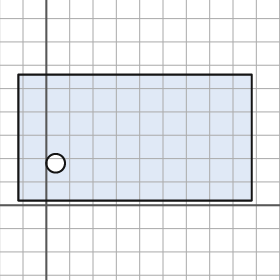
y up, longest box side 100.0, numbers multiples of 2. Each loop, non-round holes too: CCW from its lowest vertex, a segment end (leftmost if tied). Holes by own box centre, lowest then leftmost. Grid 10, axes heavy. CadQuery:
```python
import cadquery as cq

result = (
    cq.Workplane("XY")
    .moveTo(-12.0, 2.0)
    .lineTo(88.0, 2.0)
    .lineTo(88.0, 56.0)
    .lineTo(-12.0, 56.0)
    .close()
    .moveTo(4.0, 18.0)
    .circle(4.0)
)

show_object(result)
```